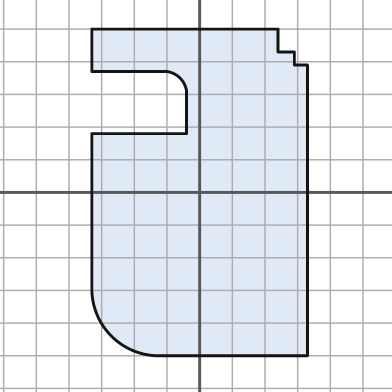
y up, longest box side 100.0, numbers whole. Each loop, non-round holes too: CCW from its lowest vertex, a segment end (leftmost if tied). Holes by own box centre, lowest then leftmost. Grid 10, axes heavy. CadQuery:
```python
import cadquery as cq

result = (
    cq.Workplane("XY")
    .moveTo(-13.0, -50.0)
    .lineTo(33.0, -50.0)
    .lineTo(33.0, 39.0)
    .lineTo(29.0, 39.0)
    .lineTo(29.0, 43.0)
    .lineTo(24.0, 43.0)
    .lineTo(24.0, 50.0)
    .lineTo(-33.0, 50.0)
    .lineTo(-33.0, 37.0)
    .lineTo(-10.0, 37.0)
    .threePointArc((-6.0, 35.0), (-4.0, 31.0))
    .lineTo(-4.0, 18.0)
    .lineTo(-33.0, 18.0)
    .lineTo(-33.0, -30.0)
    .threePointArc((-27.0, -44.0), (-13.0, -50.0))
    .close()
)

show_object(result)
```